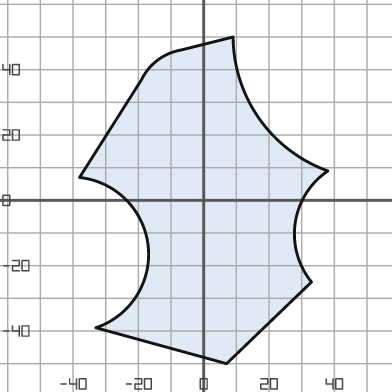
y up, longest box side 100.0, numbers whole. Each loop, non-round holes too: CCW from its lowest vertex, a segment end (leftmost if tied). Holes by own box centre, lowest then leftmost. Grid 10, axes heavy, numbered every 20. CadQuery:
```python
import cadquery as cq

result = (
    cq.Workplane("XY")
    .moveTo(7.0, -50.0)
    .lineTo(33.0, -25.0)
    .threePointArc((28.0, -7.0), (38.0, 9.0))
    .threePointArc((17.0, 25.0), (9.0, 50.0))
    .lineTo(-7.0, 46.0)
    .threePointArc((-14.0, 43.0), (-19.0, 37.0))
    .lineTo(-38.0, 7.0)
    .threePointArc((-17.0, -14.0), (-33.0, -39.0))
    .close()
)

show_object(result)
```